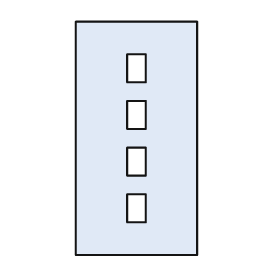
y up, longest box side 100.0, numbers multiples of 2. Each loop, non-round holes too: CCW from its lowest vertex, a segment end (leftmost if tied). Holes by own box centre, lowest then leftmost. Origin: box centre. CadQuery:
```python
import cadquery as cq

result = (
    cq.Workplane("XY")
    .moveTo(-26.0, -50.0)
    .lineTo(26.0, -50.0)
    .lineTo(26.0, 50.0)
    .lineTo(-26.0, 50.0)
    .close()
    .moveTo(-4.0, -36.0)
    .lineTo(4.0, -36.0)
    .lineTo(4.0, -24.0)
    .lineTo(-4.0, -24.0)
    .close()
    .moveTo(-4.0, -16.0)
    .lineTo(4.0, -16.0)
    .lineTo(4.0, -4.0)
    .lineTo(-4.0, -4.0)
    .close()
    .moveTo(-4.0, 4.0)
    .lineTo(4.0, 4.0)
    .lineTo(4.0, 16.0)
    .lineTo(-4.0, 16.0)
    .close()
    .moveTo(-4.0, 24.0)
    .lineTo(4.0, 24.0)
    .lineTo(4.0, 36.0)
    .lineTo(-4.0, 36.0)
    .close()
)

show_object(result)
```